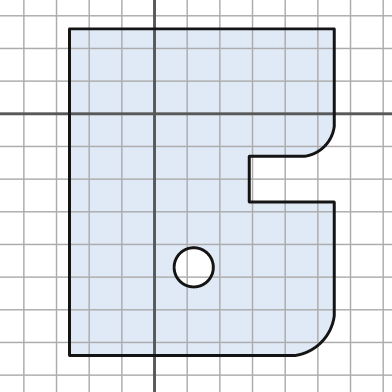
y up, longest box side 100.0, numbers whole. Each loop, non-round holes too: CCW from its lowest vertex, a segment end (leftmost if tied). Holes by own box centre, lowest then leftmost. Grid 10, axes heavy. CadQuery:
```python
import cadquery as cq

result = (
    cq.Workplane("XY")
    .moveTo(-26.0, -74.0)
    .lineTo(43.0, -74.0)
    .threePointArc((51.0, -70.0), (55.0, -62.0))
    .lineTo(55.0, -27.0)
    .lineTo(29.0, -27.0)
    .lineTo(29.0, -13.0)
    .lineTo(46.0, -13.0)
    .threePointArc((52.0, -10.0), (55.0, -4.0))
    .lineTo(55.0, 26.0)
    .lineTo(-26.0, 26.0)
    .close()
    .moveTo(12.0, -47.0)
    .circle(6.0)
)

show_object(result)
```